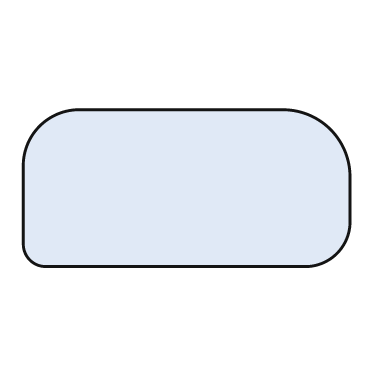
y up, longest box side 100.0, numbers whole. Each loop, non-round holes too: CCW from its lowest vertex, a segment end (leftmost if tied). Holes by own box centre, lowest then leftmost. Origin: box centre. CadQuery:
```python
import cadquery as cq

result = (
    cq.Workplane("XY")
    .moveTo(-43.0, -24.0)
    .lineTo(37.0, -24.0)
    .threePointArc((46.0, -20.0), (50.0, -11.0))
    .lineTo(50.0, 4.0)
    .threePointArc((44.0, 18.0), (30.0, 24.0))
    .lineTo(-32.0, 24.0)
    .threePointArc((-45.0, 19.0), (-50.0, 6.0))
    .lineTo(-50.0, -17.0)
    .threePointArc((-48.0, -22.0), (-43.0, -24.0))
    .close()
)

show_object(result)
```